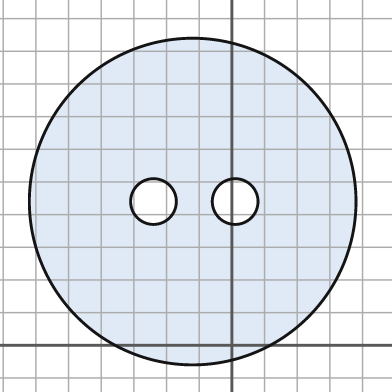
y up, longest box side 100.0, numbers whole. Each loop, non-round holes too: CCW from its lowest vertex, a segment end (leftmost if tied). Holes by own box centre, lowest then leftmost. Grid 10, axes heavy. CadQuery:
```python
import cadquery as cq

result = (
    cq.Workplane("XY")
    .moveTo(-12.0, 44.0)
    .circle(50.0)
    .moveTo(-24.0, 44.0)
    .circle(7.0)
    .moveTo(1.0, 44.0)
    .circle(7.0)
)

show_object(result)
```